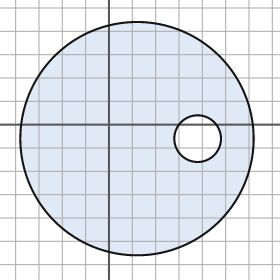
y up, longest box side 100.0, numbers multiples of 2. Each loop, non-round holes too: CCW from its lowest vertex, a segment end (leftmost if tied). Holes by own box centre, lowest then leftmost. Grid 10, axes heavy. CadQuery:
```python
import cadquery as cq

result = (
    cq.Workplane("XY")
    .moveTo(12.0, -6.0)
    .circle(50.0)
    .moveTo(38.0, -6.0)
    .circle(10.0)
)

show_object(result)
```